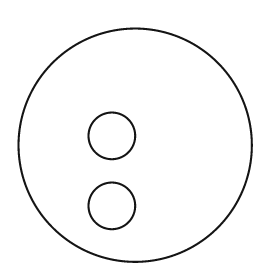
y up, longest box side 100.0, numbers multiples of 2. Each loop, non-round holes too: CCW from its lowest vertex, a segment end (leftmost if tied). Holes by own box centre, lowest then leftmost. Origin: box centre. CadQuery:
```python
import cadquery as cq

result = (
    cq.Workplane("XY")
    .moveTo(0.0, 0.0)
    .circle(50.0)
    .moveTo(-10.0, -26.0)
    .circle(10.0)
    .moveTo(-10.0, 4.0)
    .circle(10.0)
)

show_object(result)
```